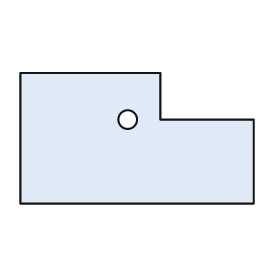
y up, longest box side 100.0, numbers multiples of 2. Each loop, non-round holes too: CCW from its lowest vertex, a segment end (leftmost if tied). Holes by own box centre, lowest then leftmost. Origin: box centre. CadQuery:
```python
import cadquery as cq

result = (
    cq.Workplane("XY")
    .moveTo(-50.0, -28.0)
    .lineTo(50.0, -28.0)
    .lineTo(50.0, 8.0)
    .lineTo(10.0, 8.0)
    .lineTo(10.0, 28.0)
    .lineTo(-50.0, 28.0)
    .close()
    .moveTo(-4.0, 8.0)
    .circle(4.0)
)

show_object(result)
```